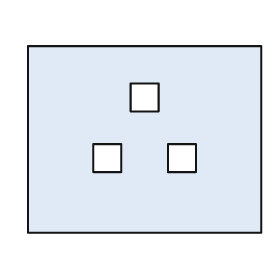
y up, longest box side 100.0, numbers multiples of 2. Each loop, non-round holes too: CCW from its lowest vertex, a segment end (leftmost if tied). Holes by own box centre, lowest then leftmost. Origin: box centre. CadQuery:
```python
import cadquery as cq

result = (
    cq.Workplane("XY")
    .moveTo(-50.0, -40.0)
    .lineTo(50.0, -40.0)
    .lineTo(50.0, 40.0)
    .lineTo(-50.0, 40.0)
    .close()
    .moveTo(-22.0, -14.0)
    .lineTo(-10.0, -14.0)
    .lineTo(-10.0, -2.0)
    .lineTo(-22.0, -2.0)
    .close()
    .moveTo(10.0, -14.0)
    .lineTo(22.0, -14.0)
    .lineTo(22.0, -2.0)
    .lineTo(10.0, -2.0)
    .close()
    .moveTo(-6.0, 12.0)
    .lineTo(6.0, 12.0)
    .lineTo(6.0, 24.0)
    .lineTo(-6.0, 24.0)
    .close()
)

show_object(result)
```